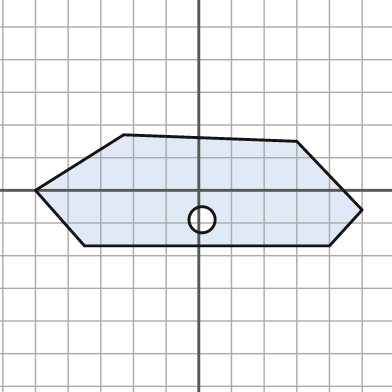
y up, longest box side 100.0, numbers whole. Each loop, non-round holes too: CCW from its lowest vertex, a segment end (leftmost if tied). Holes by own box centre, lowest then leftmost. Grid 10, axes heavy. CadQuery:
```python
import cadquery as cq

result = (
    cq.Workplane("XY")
    .moveTo(-35.0, -17.0)
    .lineTo(40.0, -17.0)
    .lineTo(50.0, -6.0)
    .lineTo(30.0, 15.0)
    .lineTo(-23.0, 17.0)
    .lineTo(-50.0, 0.0)
    .close()
    .moveTo(1.0, -9.0)
    .circle(4.0)
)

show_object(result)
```